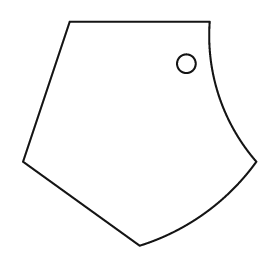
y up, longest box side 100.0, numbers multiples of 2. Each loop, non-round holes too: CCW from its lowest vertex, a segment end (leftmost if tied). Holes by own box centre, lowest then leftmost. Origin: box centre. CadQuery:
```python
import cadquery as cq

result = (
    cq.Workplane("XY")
    .moveTo(0.0, -48.0)
    .threePointArc((28.0, -34.0), (50.0, -12.0))
    .threePointArc((34.0, 16.0), (30.0, 48.0))
    .lineTo(-30.0, 48.0)
    .lineTo(-50.0, -12.0)
    .close()
    .moveTo(20.0, 30.0)
    .circle(4.0)
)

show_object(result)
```